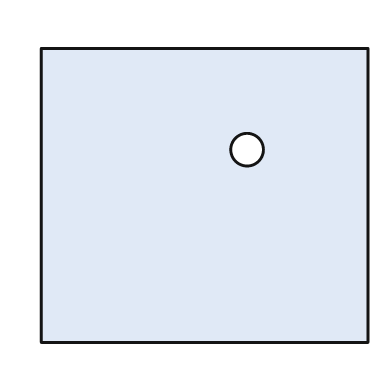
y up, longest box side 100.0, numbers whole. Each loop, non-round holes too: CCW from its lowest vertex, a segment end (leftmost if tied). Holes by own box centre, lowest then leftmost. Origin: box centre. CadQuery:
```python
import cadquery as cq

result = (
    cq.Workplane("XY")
    .moveTo(-50.0, -45.0)
    .lineTo(50.0, -45.0)
    .lineTo(50.0, 45.0)
    .lineTo(-50.0, 45.0)
    .close()
    .moveTo(13.0, 14.0)
    .circle(5.0)
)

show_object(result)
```